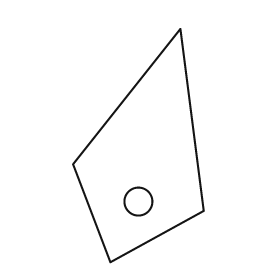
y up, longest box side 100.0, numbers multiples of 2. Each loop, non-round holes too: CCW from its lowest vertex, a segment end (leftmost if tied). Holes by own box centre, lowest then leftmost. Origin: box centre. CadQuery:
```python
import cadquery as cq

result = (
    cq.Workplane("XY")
    .moveTo(-12.0, -50.0)
    .lineTo(28.0, -28.0)
    .lineTo(18.0, 50.0)
    .lineTo(-28.0, -8.0)
    .close()
    .moveTo(0.0, -24.0)
    .circle(6.0)
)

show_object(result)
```